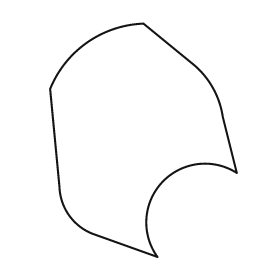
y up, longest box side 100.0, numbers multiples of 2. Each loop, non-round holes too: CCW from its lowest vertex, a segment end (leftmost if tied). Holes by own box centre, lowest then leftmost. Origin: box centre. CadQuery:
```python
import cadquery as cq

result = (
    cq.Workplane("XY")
    .moveTo(6.0, -50.0)
    .threePointArc((8.0, -18.0), (40.0, -14.0))
    .lineTo(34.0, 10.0)
    .threePointArc((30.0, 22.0), (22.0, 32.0))
    .lineTo(0.0, 50.0)
    .threePointArc((-24.0, 42.0), (-40.0, 22.0))
    .lineTo(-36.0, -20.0)
    .threePointArc((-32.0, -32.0), (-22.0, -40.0))
    .close()
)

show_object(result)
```